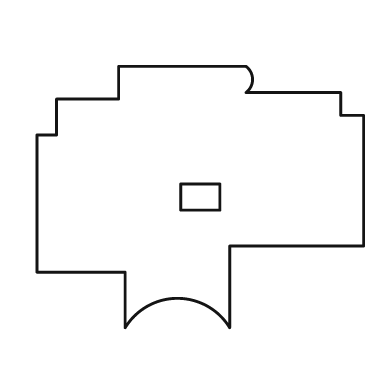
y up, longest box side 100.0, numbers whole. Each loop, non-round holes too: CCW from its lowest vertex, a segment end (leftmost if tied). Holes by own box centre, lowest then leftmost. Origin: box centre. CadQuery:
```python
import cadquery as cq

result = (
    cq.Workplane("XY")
    .moveTo(-23.0, -40.0)
    .threePointArc((-7.0, -31.0), (9.0, -40.0))
    .lineTo(9.0, -15.0)
    .lineTo(50.0, -15.0)
    .lineTo(50.0, 25.0)
    .lineTo(43.0, 25.0)
    .lineTo(43.0, 32.0)
    .lineTo(14.0, 32.0)
    .threePointArc((16.0, 36.0), (14.0, 40.0))
    .lineTo(-25.0, 40.0)
    .lineTo(-25.0, 30.0)
    .lineTo(-44.0, 30.0)
    .lineTo(-44.0, 19.0)
    .lineTo(-50.0, 19.0)
    .lineTo(-50.0, -23.0)
    .lineTo(-23.0, -23.0)
    .close()
    .moveTo(-6.0, -4.0)
    .lineTo(6.0, -4.0)
    .lineTo(6.0, 4.0)
    .lineTo(-6.0, 4.0)
    .close()
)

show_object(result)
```